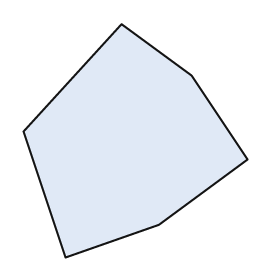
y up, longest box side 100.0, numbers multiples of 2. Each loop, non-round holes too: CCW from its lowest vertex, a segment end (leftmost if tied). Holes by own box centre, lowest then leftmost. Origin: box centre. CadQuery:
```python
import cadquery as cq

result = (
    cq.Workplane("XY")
    .moveTo(-30.0, -50.0)
    .lineTo(10.0, -36.0)
    .lineTo(48.0, -8.0)
    .lineTo(24.0, 28.0)
    .lineTo(-6.0, 50.0)
    .lineTo(-48.0, 4.0)
    .close()
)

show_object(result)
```